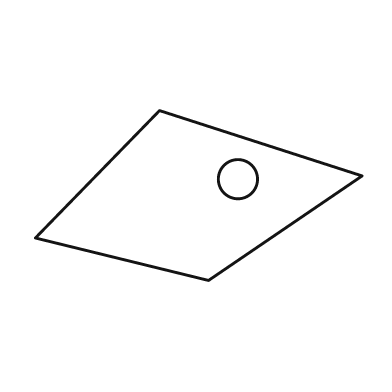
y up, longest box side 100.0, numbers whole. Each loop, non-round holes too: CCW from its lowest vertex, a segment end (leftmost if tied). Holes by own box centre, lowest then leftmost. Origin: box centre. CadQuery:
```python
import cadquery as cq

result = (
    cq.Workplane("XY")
    .moveTo(3.0, -26.0)
    .lineTo(50.0, 6.0)
    .lineTo(-12.0, 26.0)
    .lineTo(-50.0, -13.0)
    .close()
    .moveTo(12.0, 5.0)
    .circle(6.0)
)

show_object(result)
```